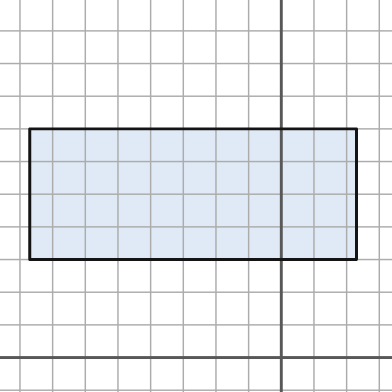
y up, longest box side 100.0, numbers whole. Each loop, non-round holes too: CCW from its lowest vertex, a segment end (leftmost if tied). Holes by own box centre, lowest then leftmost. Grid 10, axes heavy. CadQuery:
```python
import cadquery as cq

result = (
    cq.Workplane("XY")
    .moveTo(-77.0, 30.0)
    .lineTo(23.0, 30.0)
    .lineTo(23.0, 70.0)
    .lineTo(-77.0, 70.0)
    .close()
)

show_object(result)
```